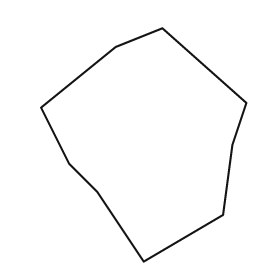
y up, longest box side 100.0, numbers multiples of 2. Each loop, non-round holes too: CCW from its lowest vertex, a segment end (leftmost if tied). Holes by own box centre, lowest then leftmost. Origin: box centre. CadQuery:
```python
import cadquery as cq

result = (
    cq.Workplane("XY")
    .moveTo(0.0, -50.0)
    .lineTo(34.0, -30.0)
    .lineTo(38.0, 0.0)
    .lineTo(44.0, 18.0)
    .lineTo(8.0, 50.0)
    .lineTo(-12.0, 42.0)
    .lineTo(-44.0, 16.0)
    .lineTo(-32.0, -8.0)
    .lineTo(-20.0, -20.0)
    .close()
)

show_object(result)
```